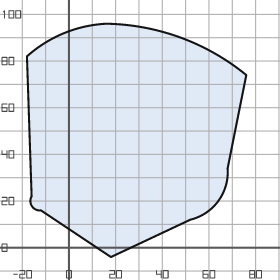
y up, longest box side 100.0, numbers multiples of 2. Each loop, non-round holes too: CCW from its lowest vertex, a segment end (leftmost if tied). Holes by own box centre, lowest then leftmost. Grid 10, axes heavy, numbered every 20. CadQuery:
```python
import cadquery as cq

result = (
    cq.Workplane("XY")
    .moveTo(18.0, -4.0)
    .lineTo(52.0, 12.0)
    .threePointArc((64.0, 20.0), (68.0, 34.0))
    .lineTo(76.0, 74.0)
    .threePointArc((48.0, 90.0), (16.0, 96.0))
    .threePointArc((-2.0, 92.0), (-18.0, 82.0))
    .lineTo(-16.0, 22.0)
    .threePointArc((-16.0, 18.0), (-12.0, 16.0))
    .close()
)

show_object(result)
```